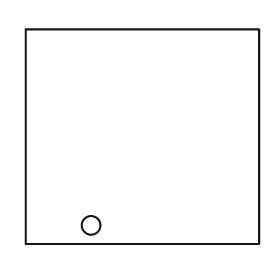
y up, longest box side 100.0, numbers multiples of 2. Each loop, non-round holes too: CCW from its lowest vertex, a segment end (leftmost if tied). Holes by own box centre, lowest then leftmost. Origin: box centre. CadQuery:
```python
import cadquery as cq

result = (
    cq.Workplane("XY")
    .moveTo(-50.0, -46.0)
    .lineTo(50.0, -46.0)
    .lineTo(50.0, 46.0)
    .lineTo(-50.0, 46.0)
    .close()
    .moveTo(-22.0, -38.0)
    .circle(4.0)
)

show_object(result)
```